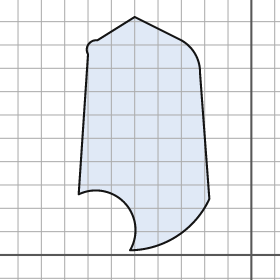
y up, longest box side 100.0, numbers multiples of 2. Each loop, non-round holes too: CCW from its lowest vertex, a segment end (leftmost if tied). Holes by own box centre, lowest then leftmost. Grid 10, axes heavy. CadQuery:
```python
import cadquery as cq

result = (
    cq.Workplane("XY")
    .moveTo(-52.0, 2.0)
    .threePointArc((-32.0, 8.0), (-18.0, 24.0))
    .lineTo(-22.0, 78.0)
    .threePointArc((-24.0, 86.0), (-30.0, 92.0))
    .lineTo(-50.0, 102.0)
    .lineTo(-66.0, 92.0)
    .threePointArc((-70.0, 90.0), (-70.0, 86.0))
    .lineTo(-74.0, 26.0)
    .threePointArc((-54.0, 22.0), (-52.0, 2.0))
    .close()
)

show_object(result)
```